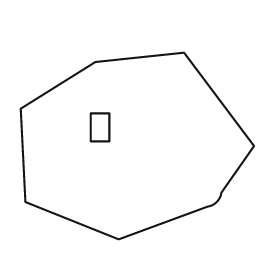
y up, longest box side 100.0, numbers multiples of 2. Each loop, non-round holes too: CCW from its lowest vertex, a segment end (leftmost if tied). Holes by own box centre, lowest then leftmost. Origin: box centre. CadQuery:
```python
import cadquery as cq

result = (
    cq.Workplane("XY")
    .moveTo(-8.0, -40.0)
    .lineTo(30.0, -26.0)
    .threePointArc((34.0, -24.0), (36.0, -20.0))
    .lineTo(50.0, 0.0)
    .lineTo(20.0, 40.0)
    .lineTo(-18.0, 36.0)
    .lineTo(-50.0, 16.0)
    .lineTo(-48.0, -24.0)
    .close()
    .moveTo(-20.0, 2.0)
    .lineTo(-12.0, 2.0)
    .lineTo(-12.0, 14.0)
    .lineTo(-20.0, 14.0)
    .close()
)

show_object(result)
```